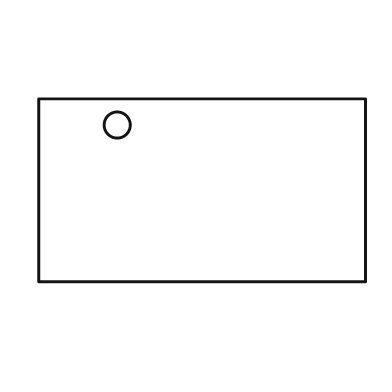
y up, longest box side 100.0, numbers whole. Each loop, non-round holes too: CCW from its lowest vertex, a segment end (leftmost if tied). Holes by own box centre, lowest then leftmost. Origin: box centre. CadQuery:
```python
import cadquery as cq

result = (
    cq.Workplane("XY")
    .moveTo(-50.0, -28.0)
    .lineTo(50.0, -28.0)
    .lineTo(50.0, 28.0)
    .lineTo(-50.0, 28.0)
    .close()
    .moveTo(-26.0, 20.0)
    .circle(4.0)
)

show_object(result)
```